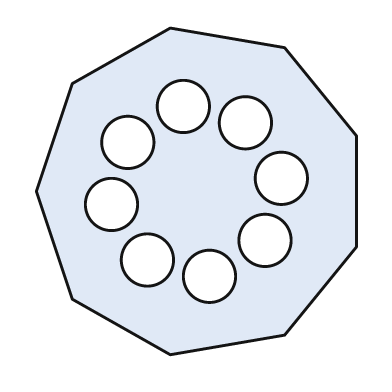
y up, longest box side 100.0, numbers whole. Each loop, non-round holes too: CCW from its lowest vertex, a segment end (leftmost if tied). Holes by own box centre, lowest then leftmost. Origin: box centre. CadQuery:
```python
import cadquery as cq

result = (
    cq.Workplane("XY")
    .moveTo(-8.0, -50.0)
    .lineTo(27.0, -44.0)
    .lineTo(49.0, -17.0)
    .lineTo(49.0, 17.0)
    .lineTo(27.0, 44.0)
    .lineTo(-8.0, 50.0)
    .lineTo(-38.0, 33.0)
    .lineTo(-49.0, 0.0)
    .lineTo(-38.0, -33.0)
    .close()
    .moveTo(4.0, -26.0)
    .circle(8.0)
    .moveTo(-15.0, -21.0)
    .circle(8.0)
    .moveTo(21.0, -15.0)
    .circle(8.0)
    .moveTo(-26.0, -4.0)
    .circle(8.0)
    .moveTo(26.0, 4.0)
    .circle(8.0)
    .moveTo(-21.0, 15.0)
    .circle(8.0)
    .moveTo(15.0, 21.0)
    .circle(8.0)
    .moveTo(-4.0, 26.0)
    .circle(8.0)
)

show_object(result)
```